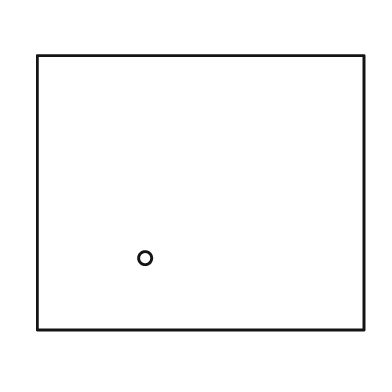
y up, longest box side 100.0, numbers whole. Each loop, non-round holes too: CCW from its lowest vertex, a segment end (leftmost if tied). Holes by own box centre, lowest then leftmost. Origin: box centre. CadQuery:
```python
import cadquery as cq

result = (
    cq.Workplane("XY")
    .moveTo(-50.0, -42.0)
    .lineTo(50.0, -42.0)
    .lineTo(50.0, 42.0)
    .lineTo(-50.0, 42.0)
    .close()
    .moveTo(-17.0, -20.0)
    .circle(2.0)
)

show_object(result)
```